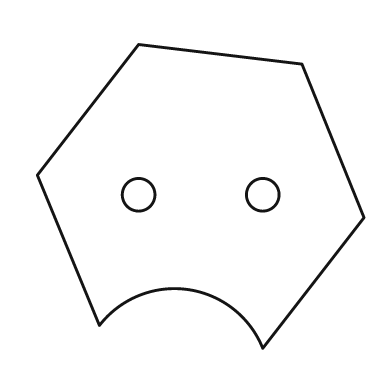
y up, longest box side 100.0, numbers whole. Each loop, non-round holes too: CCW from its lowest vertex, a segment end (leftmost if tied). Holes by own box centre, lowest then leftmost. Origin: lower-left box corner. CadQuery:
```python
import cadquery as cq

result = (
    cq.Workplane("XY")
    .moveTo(69.0, 0.0)
    .lineTo(100.0, 40.0)
    .lineTo(81.0, 87.0)
    .lineTo(31.0, 93.0)
    .lineTo(0.0, 53.0)
    .lineTo(19.0, 7.0)
    .threePointArc((46.0, 18.0), (69.0, 0.0))
    .close()
    .moveTo(31.0, 47.0)
    .circle(5.0)
    .moveTo(69.0, 47.0)
    .circle(5.0)
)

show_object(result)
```